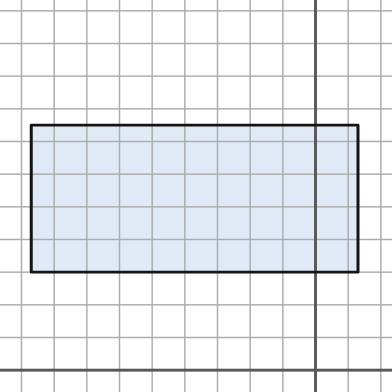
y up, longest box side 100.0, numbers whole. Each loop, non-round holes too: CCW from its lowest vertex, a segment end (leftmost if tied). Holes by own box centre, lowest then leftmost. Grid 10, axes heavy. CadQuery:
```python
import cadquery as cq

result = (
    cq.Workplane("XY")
    .moveTo(-87.0, 30.0)
    .lineTo(13.0, 30.0)
    .lineTo(13.0, 75.0)
    .lineTo(-87.0, 75.0)
    .close()
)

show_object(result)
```